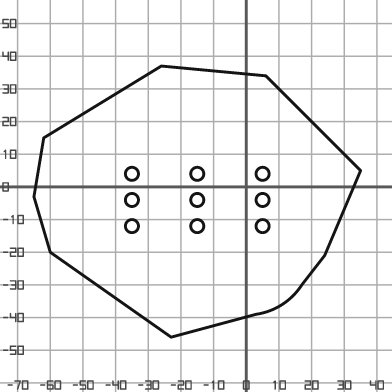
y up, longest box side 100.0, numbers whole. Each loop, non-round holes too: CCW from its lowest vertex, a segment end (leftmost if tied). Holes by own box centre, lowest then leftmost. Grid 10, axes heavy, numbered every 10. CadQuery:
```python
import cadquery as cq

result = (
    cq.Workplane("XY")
    .moveTo(-23.0, -46.0)
    .lineTo(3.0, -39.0)
    .threePointArc((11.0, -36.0), (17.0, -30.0))
    .lineTo(24.0, -21.0)
    .lineTo(35.0, 5.0)
    .lineTo(6.0, 34.0)
    .lineTo(-26.0, 37.0)
    .lineTo(-62.0, 15.0)
    .lineTo(-65.0, -3.0)
    .lineTo(-60.0, -20.0)
    .close()
    .moveTo(-35.0, -12.0)
    .circle(2.0)
    .moveTo(-15.0, -12.0)
    .circle(2.0)
    .moveTo(5.0, -12.0)
    .circle(2.0)
    .moveTo(-35.0, -4.0)
    .circle(2.0)
    .moveTo(-15.0, -4.0)
    .circle(2.0)
    .moveTo(5.0, -4.0)
    .circle(2.0)
    .moveTo(-35.0, 4.0)
    .circle(2.0)
    .moveTo(-15.0, 4.0)
    .circle(2.0)
    .moveTo(5.0, 4.0)
    .circle(2.0)
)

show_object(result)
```